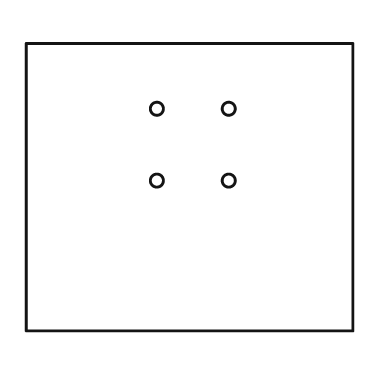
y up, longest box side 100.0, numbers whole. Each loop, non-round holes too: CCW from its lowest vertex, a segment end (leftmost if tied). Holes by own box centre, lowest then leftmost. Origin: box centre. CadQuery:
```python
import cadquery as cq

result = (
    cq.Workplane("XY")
    .moveTo(-50.0, -44.0)
    .lineTo(50.0, -44.0)
    .lineTo(50.0, 44.0)
    .lineTo(-50.0, 44.0)
    .close()
    .moveTo(-10.0, 2.0)
    .circle(2.0)
    .moveTo(12.0, 2.0)
    .circle(2.0)
    .moveTo(-10.0, 24.0)
    .circle(2.0)
    .moveTo(12.0, 24.0)
    .circle(2.0)
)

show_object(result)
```